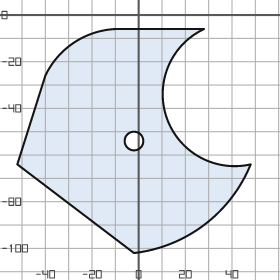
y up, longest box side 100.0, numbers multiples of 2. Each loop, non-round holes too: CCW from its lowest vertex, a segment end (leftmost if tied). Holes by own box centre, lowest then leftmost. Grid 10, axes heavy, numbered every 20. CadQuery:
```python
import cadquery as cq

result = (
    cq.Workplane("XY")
    .moveTo(-2.0, -102.0)
    .threePointArc((28.0, -90.0), (48.0, -64.0))
    .threePointArc((12.0, -44.0), (28.0, -6.0))
    .lineTo(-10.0, -6.0)
    .threePointArc((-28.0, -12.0), (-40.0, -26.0))
    .lineTo(-52.0, -64.0)
    .close()
    .moveTo(-2.0, -54.0)
    .circle(4.0)
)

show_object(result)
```